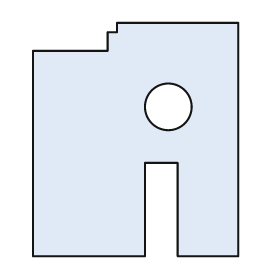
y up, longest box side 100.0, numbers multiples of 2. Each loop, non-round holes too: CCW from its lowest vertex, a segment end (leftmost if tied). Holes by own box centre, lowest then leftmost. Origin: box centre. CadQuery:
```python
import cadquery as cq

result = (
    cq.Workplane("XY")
    .moveTo(-44.0, -50.0)
    .lineTo(4.0, -50.0)
    .lineTo(4.0, -10.0)
    .lineTo(18.0, -10.0)
    .lineTo(18.0, -50.0)
    .lineTo(44.0, -50.0)
    .lineTo(44.0, 50.0)
    .lineTo(-8.0, 50.0)
    .lineTo(-8.0, 46.0)
    .lineTo(-12.0, 46.0)
    .lineTo(-12.0, 38.0)
    .lineTo(-44.0, 38.0)
    .close()
    .moveTo(14.0, 14.0)
    .circle(10.0)
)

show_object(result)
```